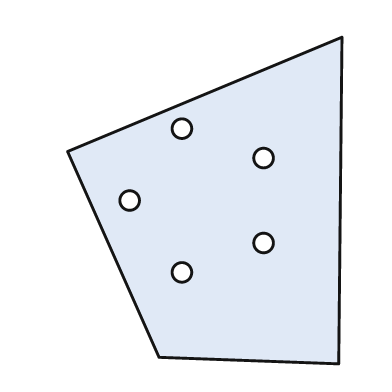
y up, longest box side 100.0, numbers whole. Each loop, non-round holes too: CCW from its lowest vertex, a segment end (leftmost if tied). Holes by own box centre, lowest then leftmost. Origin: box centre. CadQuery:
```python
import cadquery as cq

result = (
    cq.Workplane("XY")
    .moveTo(41.0, -50.0)
    .lineTo(42.0, 50.0)
    .lineTo(-42.0, 15.0)
    .lineTo(-14.0, -48.0)
    .close()
    .moveTo(-7.0, -22.0)
    .circle(3.0)
    .moveTo(18.0, -13.0)
    .circle(3.0)
    .moveTo(-23.0, 0.0)
    .circle(3.0)
    .moveTo(18.0, 13.0)
    .circle(3.0)
    .moveTo(-7.0, 22.0)
    .circle(3.0)
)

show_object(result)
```